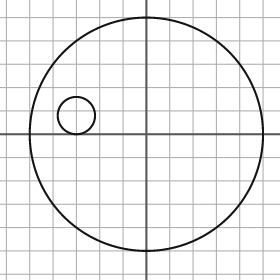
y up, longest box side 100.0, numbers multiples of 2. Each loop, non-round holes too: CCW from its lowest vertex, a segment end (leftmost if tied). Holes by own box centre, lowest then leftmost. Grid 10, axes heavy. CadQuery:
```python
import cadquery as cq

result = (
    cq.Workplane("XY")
    .moveTo(0.0, 0.0)
    .circle(50.0)
    .moveTo(-30.0, 8.0)
    .circle(8.0)
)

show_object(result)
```